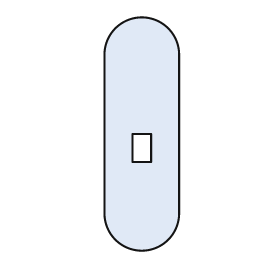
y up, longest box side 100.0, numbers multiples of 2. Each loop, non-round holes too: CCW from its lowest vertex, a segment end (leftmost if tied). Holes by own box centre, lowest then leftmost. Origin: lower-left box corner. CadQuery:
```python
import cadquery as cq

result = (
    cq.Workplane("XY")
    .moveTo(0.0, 16.0)
    .threePointArc((16.0, 0.0), (32.0, 16.0))
    .lineTo(32.0, 84.0)
    .threePointArc((16.0, 100.0), (0.0, 84.0))
    .close()
    .moveTo(12.0, 38.0)
    .lineTo(20.0, 38.0)
    .lineTo(20.0, 50.0)
    .lineTo(12.0, 50.0)
    .close()
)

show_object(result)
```